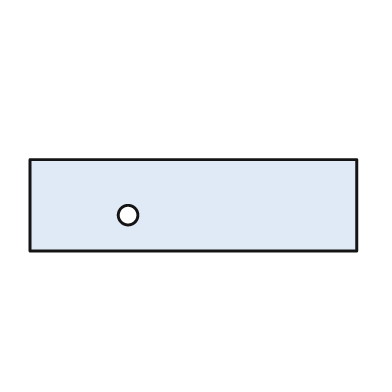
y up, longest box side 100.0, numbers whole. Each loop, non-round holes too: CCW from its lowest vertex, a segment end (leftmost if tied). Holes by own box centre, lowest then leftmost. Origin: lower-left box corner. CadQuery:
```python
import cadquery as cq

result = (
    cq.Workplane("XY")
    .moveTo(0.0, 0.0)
    .lineTo(100.0, 0.0)
    .lineTo(100.0, 28.0)
    .lineTo(0.0, 28.0)
    .close()
    .moveTo(30.0, 11.0)
    .circle(3.0)
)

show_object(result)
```